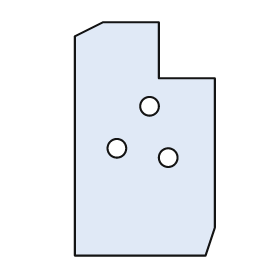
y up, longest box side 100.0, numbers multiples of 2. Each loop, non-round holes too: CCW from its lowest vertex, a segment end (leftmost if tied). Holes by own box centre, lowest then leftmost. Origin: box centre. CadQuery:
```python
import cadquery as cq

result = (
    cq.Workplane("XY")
    .moveTo(-30.0, -50.0)
    .lineTo(26.0, -50.0)
    .lineTo(30.0, -38.0)
    .lineTo(30.0, 26.0)
    .lineTo(6.0, 26.0)
    .lineTo(6.0, 50.0)
    .lineTo(-18.0, 50.0)
    .lineTo(-30.0, 44.0)
    .close()
    .moveTo(10.0, -8.0)
    .circle(4.0)
    .moveTo(-12.0, -4.0)
    .circle(4.0)
    .moveTo(2.0, 14.0)
    .circle(4.0)
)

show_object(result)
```